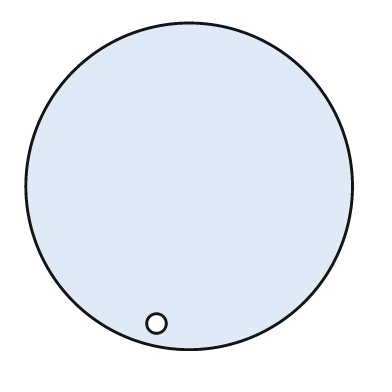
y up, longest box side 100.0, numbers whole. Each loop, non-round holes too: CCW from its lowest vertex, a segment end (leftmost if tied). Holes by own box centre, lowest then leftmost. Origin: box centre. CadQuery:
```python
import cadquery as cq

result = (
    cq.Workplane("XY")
    .moveTo(0.0, 0.0)
    .circle(50.0)
    .moveTo(-10.0, -42.0)
    .circle(3.0)
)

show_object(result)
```